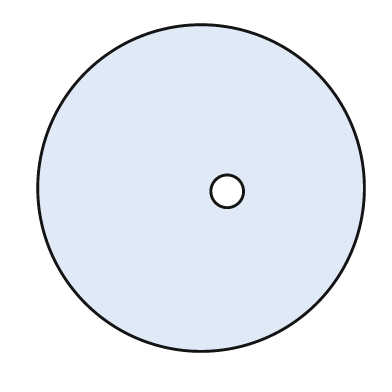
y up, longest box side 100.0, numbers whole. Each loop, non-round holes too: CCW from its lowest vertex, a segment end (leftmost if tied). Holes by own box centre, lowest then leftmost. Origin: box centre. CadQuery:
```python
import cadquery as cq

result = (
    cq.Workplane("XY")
    .moveTo(0.0, 0.0)
    .circle(50.0)
    .moveTo(8.0, -1.0)
    .circle(5.0)
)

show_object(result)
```